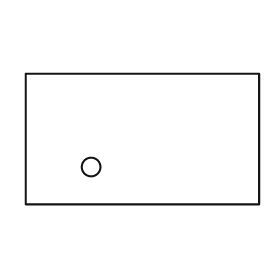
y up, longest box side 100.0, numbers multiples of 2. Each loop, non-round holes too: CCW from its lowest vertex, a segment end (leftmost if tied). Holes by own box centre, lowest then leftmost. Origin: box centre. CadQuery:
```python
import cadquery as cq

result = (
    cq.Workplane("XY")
    .moveTo(-50.0, -28.0)
    .lineTo(50.0, -28.0)
    .lineTo(50.0, 28.0)
    .lineTo(-50.0, 28.0)
    .close()
    .moveTo(-22.0, -12.0)
    .circle(4.0)
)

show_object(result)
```